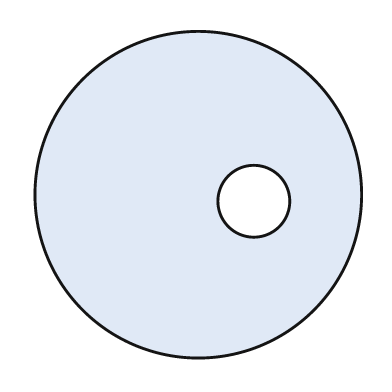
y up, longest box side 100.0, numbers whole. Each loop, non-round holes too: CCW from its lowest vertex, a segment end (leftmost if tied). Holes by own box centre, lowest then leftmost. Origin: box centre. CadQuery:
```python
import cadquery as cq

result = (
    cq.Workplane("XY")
    .moveTo(0.0, 0.0)
    .circle(50.0)
    .moveTo(17.0, -2.0)
    .circle(11.0)
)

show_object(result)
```